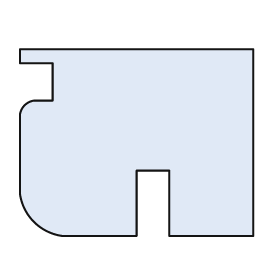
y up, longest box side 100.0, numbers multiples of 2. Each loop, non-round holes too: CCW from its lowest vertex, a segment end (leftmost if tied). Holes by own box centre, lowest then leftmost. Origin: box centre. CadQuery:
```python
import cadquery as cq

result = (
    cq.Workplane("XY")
    .moveTo(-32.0, -40.0)
    .lineTo(0.0, -40.0)
    .lineTo(0.0, -12.0)
    .lineTo(14.0, -12.0)
    .lineTo(14.0, -40.0)
    .lineTo(50.0, -40.0)
    .lineTo(50.0, 40.0)
    .lineTo(-50.0, 40.0)
    .lineTo(-50.0, 34.0)
    .lineTo(-36.0, 34.0)
    .lineTo(-36.0, 18.0)
    .lineTo(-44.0, 18.0)
    .threePointArc((-48.0, 16.0), (-50.0, 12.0))
    .lineTo(-50.0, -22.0)
    .threePointArc((-44.0, -34.0), (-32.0, -40.0))
    .close()
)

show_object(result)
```